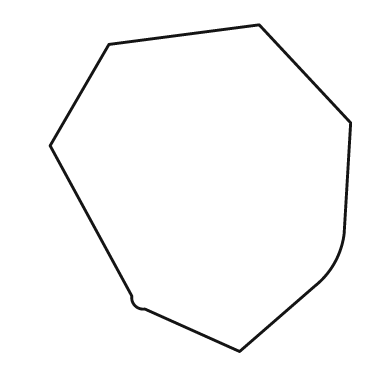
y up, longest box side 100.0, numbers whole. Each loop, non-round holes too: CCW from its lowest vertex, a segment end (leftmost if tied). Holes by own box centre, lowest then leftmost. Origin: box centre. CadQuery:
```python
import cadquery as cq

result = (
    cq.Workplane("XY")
    .moveTo(12.0, -50.0)
    .lineTo(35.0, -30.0)
    .threePointArc((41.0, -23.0), (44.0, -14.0))
    .lineTo(46.0, 20.0)
    .lineTo(18.0, 50.0)
    .lineTo(-28.0, 44.0)
    .lineTo(-46.0, 13.0)
    .lineTo(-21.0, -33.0)
    .threePointArc((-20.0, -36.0), (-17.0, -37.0))
    .close()
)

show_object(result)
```